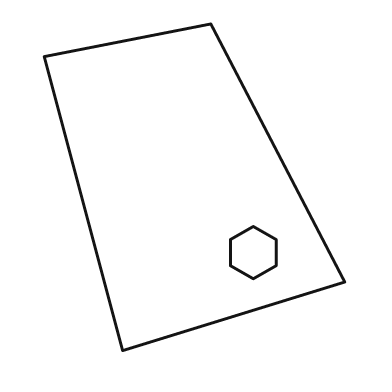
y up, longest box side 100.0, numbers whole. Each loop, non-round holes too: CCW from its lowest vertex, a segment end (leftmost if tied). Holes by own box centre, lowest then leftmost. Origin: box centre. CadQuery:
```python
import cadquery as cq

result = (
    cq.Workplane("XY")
    .moveTo(-22.0, -50.0)
    .lineTo(46.0, -29.0)
    .lineTo(5.0, 50.0)
    .lineTo(-46.0, 40.0)
    .close()
    .moveTo(18.0, -28.0)
    .lineTo(25.0, -24.0)
    .lineTo(25.0, -16.0)
    .lineTo(18.0, -12.0)
    .lineTo(11.0, -16.0)
    .lineTo(11.0, -24.0)
    .close()
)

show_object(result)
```